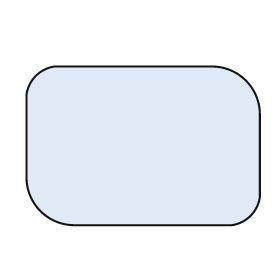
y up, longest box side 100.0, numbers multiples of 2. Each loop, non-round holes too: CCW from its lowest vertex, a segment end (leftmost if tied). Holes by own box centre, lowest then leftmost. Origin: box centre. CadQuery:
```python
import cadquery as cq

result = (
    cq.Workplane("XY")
    .moveTo(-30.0, -34.0)
    .lineTo(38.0, -34.0)
    .threePointArc((46.0, -30.0), (50.0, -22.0))
    .lineTo(50.0, 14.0)
    .threePointArc((44.0, 28.0), (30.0, 34.0))
    .lineTo(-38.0, 34.0)
    .threePointArc((-46.0, 30.0), (-50.0, 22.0))
    .lineTo(-50.0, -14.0)
    .threePointArc((-44.0, -28.0), (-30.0, -34.0))
    .close()
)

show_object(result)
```